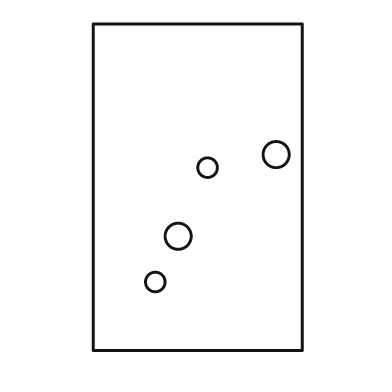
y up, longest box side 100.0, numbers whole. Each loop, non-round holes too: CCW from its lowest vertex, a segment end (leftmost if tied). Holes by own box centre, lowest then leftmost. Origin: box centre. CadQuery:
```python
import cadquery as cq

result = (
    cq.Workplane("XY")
    .moveTo(-32.0, -50.0)
    .lineTo(32.0, -50.0)
    .lineTo(32.0, 50.0)
    .lineTo(-32.0, 50.0)
    .close()
    .moveTo(-13.0, -29.0)
    .circle(3.0)
    .moveTo(-6.0, -15.0)
    .circle(4.0)
    .moveTo(3.0, 6.0)
    .circle(3.0)
    .moveTo(24.0, 10.0)
    .circle(4.0)
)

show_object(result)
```